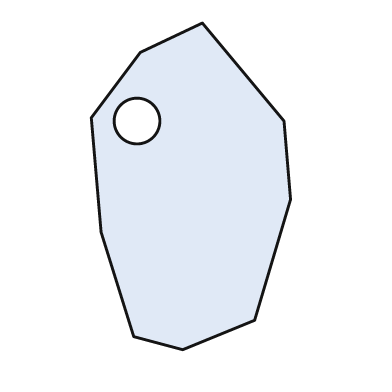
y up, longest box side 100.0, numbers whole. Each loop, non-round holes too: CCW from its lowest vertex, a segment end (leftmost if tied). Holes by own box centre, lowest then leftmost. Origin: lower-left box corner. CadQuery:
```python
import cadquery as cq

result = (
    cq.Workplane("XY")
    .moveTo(28.0, 0.0)
    .lineTo(50.0, 9.0)
    .lineTo(61.0, 46.0)
    .lineTo(59.0, 70.0)
    .lineTo(34.0, 100.0)
    .lineTo(15.0, 91.0)
    .lineTo(0.0, 71.0)
    .lineTo(3.0, 36.0)
    .lineTo(13.0, 4.0)
    .close()
    .moveTo(14.0, 70.0)
    .circle(7.0)
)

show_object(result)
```